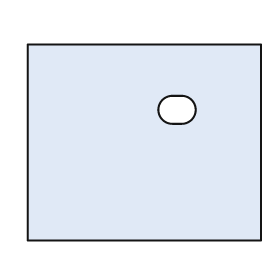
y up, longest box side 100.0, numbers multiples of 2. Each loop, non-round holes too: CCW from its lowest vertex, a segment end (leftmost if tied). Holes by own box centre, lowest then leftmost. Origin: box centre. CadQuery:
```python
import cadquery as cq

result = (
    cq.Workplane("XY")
    .moveTo(-50.0, -42.0)
    .lineTo(50.0, -42.0)
    .lineTo(50.0, 42.0)
    .lineTo(-50.0, 42.0)
    .close()
    .moveTo(12.0, 8.0)
    .lineTo(16.0, 8.0)
    .threePointArc((22.0, 14.0), (16.0, 20.0))
    .lineTo(12.0, 20.0)
    .threePointArc((6.0, 14.0), (12.0, 8.0))
    .close()
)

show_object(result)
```